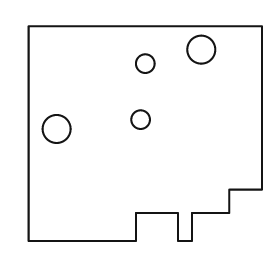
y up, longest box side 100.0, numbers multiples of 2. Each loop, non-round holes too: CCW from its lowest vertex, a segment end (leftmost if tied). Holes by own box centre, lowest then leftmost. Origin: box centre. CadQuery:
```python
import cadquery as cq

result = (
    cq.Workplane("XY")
    .moveTo(-50.0, -46.0)
    .lineTo(-4.0, -46.0)
    .lineTo(-4.0, -34.0)
    .lineTo(14.0, -34.0)
    .lineTo(14.0, -46.0)
    .lineTo(20.0, -46.0)
    .lineTo(20.0, -34.0)
    .lineTo(36.0, -34.0)
    .lineTo(36.0, -24.0)
    .lineTo(50.0, -24.0)
    .lineTo(50.0, 46.0)
    .lineTo(-50.0, 46.0)
    .close()
    .moveTo(-38.0, 2.0)
    .circle(6.0)
    .moveTo(-2.0, 6.0)
    .circle(4.0)
    .moveTo(0.0, 30.0)
    .circle(4.0)
    .moveTo(24.0, 36.0)
    .circle(6.0)
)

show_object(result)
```